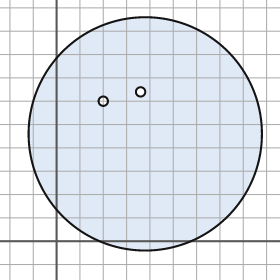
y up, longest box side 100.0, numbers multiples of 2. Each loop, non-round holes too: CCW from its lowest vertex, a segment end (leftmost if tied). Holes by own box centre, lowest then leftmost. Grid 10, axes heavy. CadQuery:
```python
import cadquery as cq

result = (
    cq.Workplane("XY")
    .moveTo(38.0, 46.0)
    .circle(50.0)
    .moveTo(20.0, 60.0)
    .circle(2.0)
    .moveTo(36.0, 64.0)
    .circle(2.0)
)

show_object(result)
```